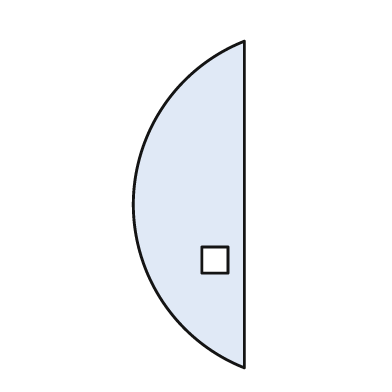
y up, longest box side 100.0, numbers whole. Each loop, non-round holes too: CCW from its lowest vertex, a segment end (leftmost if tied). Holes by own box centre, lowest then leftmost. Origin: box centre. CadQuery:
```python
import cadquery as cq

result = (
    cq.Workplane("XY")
    .moveTo(17.0, -50.0)
    .lineTo(17.0, 50.0)
    .threePointArc((-17.0, 0.0), (17.0, -50.0))
    .close()
    .moveTo(4.0, -21.0)
    .lineTo(12.0, -21.0)
    .lineTo(12.0, -13.0)
    .lineTo(4.0, -13.0)
    .close()
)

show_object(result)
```